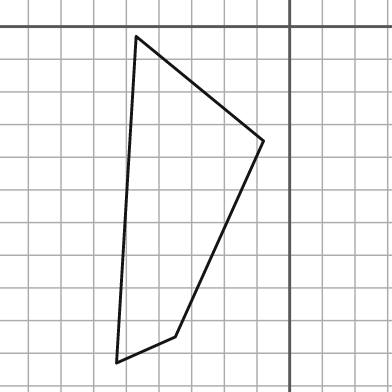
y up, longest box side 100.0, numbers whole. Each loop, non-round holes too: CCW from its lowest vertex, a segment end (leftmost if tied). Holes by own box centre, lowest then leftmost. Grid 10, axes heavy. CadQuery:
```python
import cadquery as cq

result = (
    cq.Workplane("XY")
    .moveTo(-53.0, -103.0)
    .lineTo(-35.0, -95.0)
    .lineTo(-8.0, -35.0)
    .lineTo(-47.0, -3.0)
    .close()
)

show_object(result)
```